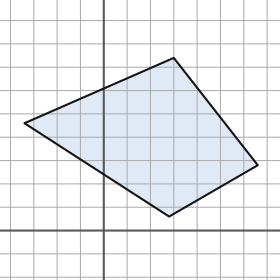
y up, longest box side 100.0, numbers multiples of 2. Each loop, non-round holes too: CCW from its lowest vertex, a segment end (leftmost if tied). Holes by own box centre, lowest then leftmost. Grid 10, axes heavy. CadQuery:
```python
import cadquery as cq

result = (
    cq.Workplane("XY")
    .moveTo(28.0, 6.0)
    .lineTo(66.0, 28.0)
    .lineTo(30.0, 74.0)
    .lineTo(-34.0, 46.0)
    .close()
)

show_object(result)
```